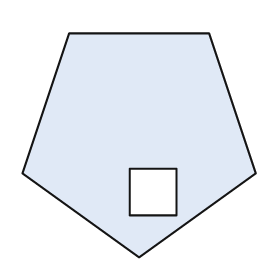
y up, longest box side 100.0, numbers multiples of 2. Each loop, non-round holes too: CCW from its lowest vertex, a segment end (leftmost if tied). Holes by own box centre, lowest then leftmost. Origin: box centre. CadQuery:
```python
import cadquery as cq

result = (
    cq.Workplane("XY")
    .moveTo(0.0, -48.0)
    .lineTo(50.0, -12.0)
    .lineTo(30.0, 48.0)
    .lineTo(-30.0, 48.0)
    .lineTo(-50.0, -12.0)
    .close()
    .moveTo(-4.0, -30.0)
    .lineTo(16.0, -30.0)
    .lineTo(16.0, -10.0)
    .lineTo(-4.0, -10.0)
    .close()
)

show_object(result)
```